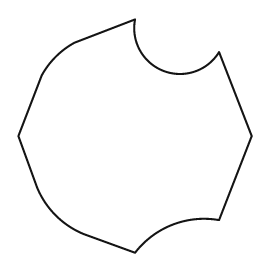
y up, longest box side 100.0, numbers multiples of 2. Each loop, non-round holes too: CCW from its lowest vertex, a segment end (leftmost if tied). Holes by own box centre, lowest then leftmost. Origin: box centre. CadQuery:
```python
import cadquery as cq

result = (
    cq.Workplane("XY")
    .moveTo(0.0, -50.0)
    .threePointArc((16.0, -38.0), (36.0, -36.0))
    .lineTo(50.0, 0.0)
    .lineTo(36.0, 36.0)
    .threePointArc((12.0, 28.0), (0.0, 50.0))
    .lineTo(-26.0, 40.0)
    .threePointArc((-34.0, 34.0), (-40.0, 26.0))
    .lineTo(-50.0, 0.0)
    .lineTo(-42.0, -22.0)
    .threePointArc((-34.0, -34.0), (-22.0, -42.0))
    .close()
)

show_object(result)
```